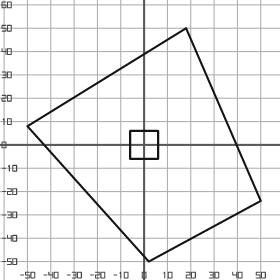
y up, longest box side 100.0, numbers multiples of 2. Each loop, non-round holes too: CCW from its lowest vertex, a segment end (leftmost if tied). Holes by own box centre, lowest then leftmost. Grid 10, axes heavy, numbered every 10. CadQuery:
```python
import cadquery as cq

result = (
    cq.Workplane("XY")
    .moveTo(2.0, -50.0)
    .lineTo(50.0, -24.0)
    .lineTo(18.0, 50.0)
    .lineTo(-50.0, 8.0)
    .close()
    .moveTo(-6.0, -6.0)
    .lineTo(6.0, -6.0)
    .lineTo(6.0, 6.0)
    .lineTo(-6.0, 6.0)
    .close()
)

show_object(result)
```